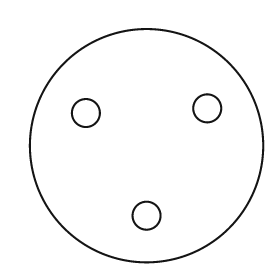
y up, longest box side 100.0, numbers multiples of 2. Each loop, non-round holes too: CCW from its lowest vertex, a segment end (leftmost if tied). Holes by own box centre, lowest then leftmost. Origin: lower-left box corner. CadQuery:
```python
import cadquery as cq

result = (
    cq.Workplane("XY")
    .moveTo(50.0, 50.0)
    .circle(50.0)
    .moveTo(50.0, 20.0)
    .circle(6.0)
    .moveTo(24.0, 64.0)
    .circle(6.0)
    .moveTo(76.0, 66.0)
    .circle(6.0)
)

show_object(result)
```